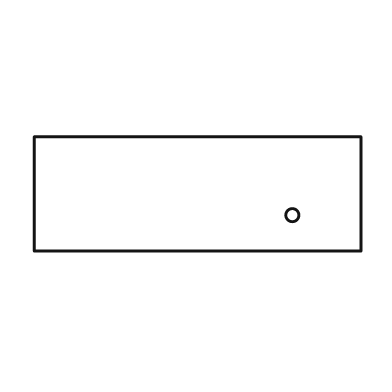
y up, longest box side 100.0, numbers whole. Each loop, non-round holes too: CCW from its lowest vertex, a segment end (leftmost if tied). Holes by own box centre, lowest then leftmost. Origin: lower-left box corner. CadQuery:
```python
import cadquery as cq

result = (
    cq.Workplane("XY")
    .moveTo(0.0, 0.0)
    .lineTo(100.0, 0.0)
    .lineTo(100.0, 35.0)
    .lineTo(0.0, 35.0)
    .close()
    .moveTo(79.0, 11.0)
    .circle(2.0)
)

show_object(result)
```